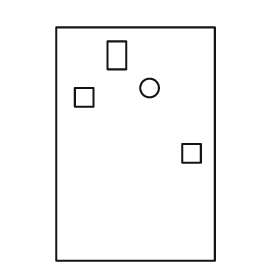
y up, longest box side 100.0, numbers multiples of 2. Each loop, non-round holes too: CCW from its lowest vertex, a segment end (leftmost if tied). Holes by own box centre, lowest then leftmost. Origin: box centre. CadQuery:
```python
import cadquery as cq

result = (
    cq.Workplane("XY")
    .moveTo(-34.0, -50.0)
    .lineTo(34.0, -50.0)
    .lineTo(34.0, 50.0)
    .lineTo(-34.0, 50.0)
    .close()
    .moveTo(20.0, -8.0)
    .lineTo(28.0, -8.0)
    .lineTo(28.0, 0.0)
    .lineTo(20.0, 0.0)
    .close()
    .moveTo(-26.0, 16.0)
    .lineTo(-18.0, 16.0)
    .lineTo(-18.0, 24.0)
    .lineTo(-26.0, 24.0)
    .close()
    .moveTo(6.0, 24.0)
    .circle(4.0)
    .moveTo(-12.0, 32.0)
    .lineTo(-4.0, 32.0)
    .lineTo(-4.0, 44.0)
    .lineTo(-12.0, 44.0)
    .close()
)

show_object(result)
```